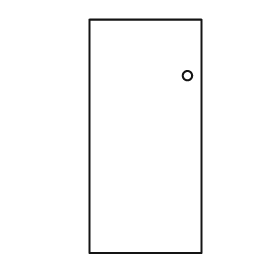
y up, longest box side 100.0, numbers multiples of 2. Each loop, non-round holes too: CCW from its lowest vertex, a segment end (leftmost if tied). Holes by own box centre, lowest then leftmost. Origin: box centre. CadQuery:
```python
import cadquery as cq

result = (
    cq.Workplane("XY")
    .moveTo(-24.0, -50.0)
    .lineTo(24.0, -50.0)
    .lineTo(24.0, 50.0)
    .lineTo(-24.0, 50.0)
    .close()
    .moveTo(18.0, 26.0)
    .circle(2.0)
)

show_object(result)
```